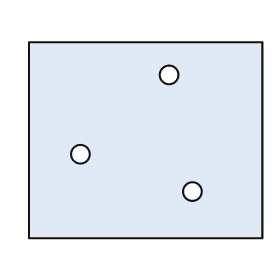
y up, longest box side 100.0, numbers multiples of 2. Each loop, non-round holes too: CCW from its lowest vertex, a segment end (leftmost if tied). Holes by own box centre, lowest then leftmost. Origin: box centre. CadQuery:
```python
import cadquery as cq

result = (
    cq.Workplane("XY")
    .moveTo(-50.0, -42.0)
    .lineTo(50.0, -42.0)
    .lineTo(50.0, 42.0)
    .lineTo(-50.0, 42.0)
    .close()
    .moveTo(20.0, -22.0)
    .circle(4.0)
    .moveTo(-28.0, -6.0)
    .circle(4.0)
    .moveTo(10.0, 28.0)
    .circle(4.0)
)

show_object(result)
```